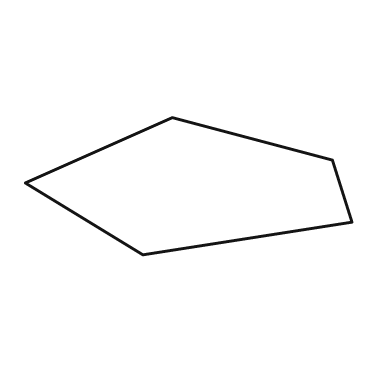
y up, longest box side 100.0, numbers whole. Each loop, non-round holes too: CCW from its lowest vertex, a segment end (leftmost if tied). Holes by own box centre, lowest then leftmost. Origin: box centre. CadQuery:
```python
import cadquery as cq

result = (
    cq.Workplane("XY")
    .moveTo(-14.0, -21.0)
    .lineTo(50.0, -11.0)
    .lineTo(44.0, 8.0)
    .lineTo(-5.0, 21.0)
    .lineTo(-50.0, 1.0)
    .close()
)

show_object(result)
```